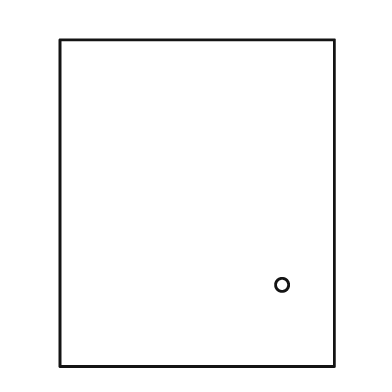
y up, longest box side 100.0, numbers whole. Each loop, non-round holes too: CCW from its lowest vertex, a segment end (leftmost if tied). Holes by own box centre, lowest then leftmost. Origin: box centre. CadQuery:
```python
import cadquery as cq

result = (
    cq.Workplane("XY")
    .moveTo(-42.0, -50.0)
    .lineTo(42.0, -50.0)
    .lineTo(42.0, 50.0)
    .lineTo(-42.0, 50.0)
    .close()
    .moveTo(26.0, -25.0)
    .circle(2.0)
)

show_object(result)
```